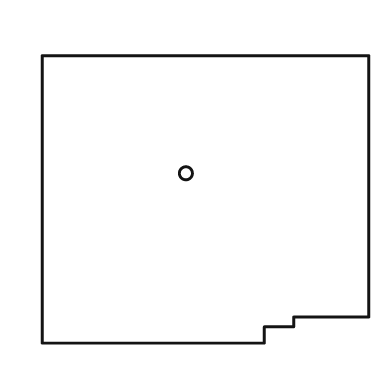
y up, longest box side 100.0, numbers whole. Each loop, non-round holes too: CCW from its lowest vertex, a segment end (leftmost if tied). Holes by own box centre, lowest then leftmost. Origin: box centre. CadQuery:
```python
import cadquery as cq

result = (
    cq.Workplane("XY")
    .moveTo(-50.0, -44.0)
    .lineTo(18.0, -44.0)
    .lineTo(18.0, -39.0)
    .lineTo(27.0, -39.0)
    .lineTo(27.0, -36.0)
    .lineTo(50.0, -36.0)
    .lineTo(50.0, 44.0)
    .lineTo(-50.0, 44.0)
    .close()
    .moveTo(-6.0, 8.0)
    .circle(2.0)
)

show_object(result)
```